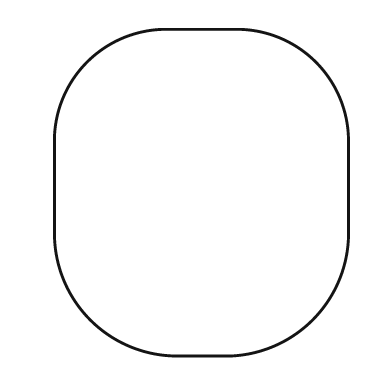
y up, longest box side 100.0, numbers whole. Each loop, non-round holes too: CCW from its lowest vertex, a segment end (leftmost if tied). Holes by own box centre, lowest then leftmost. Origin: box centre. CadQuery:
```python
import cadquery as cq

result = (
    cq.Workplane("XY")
    .moveTo(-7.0, -50.0)
    .lineTo(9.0, -50.0)
    .threePointArc((34.0, -39.0), (45.0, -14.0))
    .lineTo(45.0, 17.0)
    .threePointArc((35.0, 40.0), (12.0, 50.0))
    .lineTo(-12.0, 50.0)
    .threePointArc((-35.0, 40.0), (-45.0, 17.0))
    .lineTo(-45.0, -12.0)
    .threePointArc((-34.0, -39.0), (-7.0, -50.0))
    .close()
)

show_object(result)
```